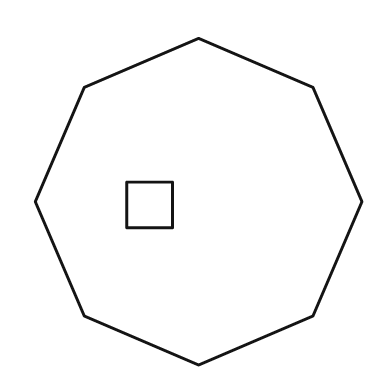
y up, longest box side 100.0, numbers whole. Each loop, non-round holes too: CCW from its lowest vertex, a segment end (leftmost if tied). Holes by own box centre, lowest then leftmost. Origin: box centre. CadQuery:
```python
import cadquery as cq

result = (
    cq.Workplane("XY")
    .moveTo(0.0, -50.0)
    .lineTo(35.0, -35.0)
    .lineTo(50.0, 0.0)
    .lineTo(35.0, 35.0)
    .lineTo(0.0, 50.0)
    .lineTo(-35.0, 35.0)
    .lineTo(-50.0, 0.0)
    .lineTo(-35.0, -35.0)
    .close()
    .moveTo(-22.0, -8.0)
    .lineTo(-8.0, -8.0)
    .lineTo(-8.0, 6.0)
    .lineTo(-22.0, 6.0)
    .close()
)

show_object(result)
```